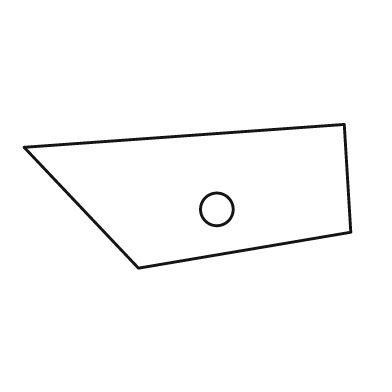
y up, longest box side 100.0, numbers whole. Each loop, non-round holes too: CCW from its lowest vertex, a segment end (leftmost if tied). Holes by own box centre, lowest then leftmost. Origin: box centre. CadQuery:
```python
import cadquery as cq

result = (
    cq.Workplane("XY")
    .moveTo(-15.0, -22.0)
    .lineTo(50.0, -11.0)
    .lineTo(48.0, 22.0)
    .lineTo(-50.0, 15.0)
    .close()
    .moveTo(9.0, -4.0)
    .circle(5.0)
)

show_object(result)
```